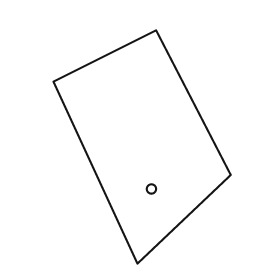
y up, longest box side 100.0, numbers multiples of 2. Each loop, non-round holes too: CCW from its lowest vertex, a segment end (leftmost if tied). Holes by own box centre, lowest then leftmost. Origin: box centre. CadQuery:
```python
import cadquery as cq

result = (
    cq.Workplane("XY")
    .moveTo(-2.0, -50.0)
    .lineTo(38.0, -12.0)
    .lineTo(6.0, 50.0)
    .lineTo(-38.0, 28.0)
    .close()
    .moveTo(4.0, -18.0)
    .circle(2.0)
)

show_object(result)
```